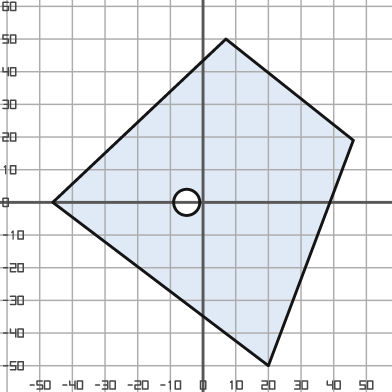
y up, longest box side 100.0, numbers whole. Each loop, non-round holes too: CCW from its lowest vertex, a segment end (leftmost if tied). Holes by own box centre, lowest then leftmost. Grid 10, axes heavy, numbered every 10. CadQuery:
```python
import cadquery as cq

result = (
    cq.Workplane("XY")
    .moveTo(20.0, -50.0)
    .lineTo(46.0, 19.0)
    .lineTo(7.0, 50.0)
    .lineTo(-46.0, 0.0)
    .close()
    .moveTo(-5.0, 0.0)
    .circle(4.0)
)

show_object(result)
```